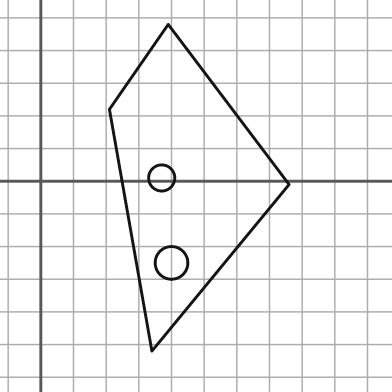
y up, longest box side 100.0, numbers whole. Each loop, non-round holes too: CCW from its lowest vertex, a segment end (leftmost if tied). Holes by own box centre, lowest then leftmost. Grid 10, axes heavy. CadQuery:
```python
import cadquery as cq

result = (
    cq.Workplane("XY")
    .moveTo(34.0, -52.0)
    .lineTo(76.0, -1.0)
    .lineTo(39.0, 48.0)
    .lineTo(21.0, 22.0)
    .close()
    .moveTo(40.0, -25.0)
    .circle(5.0)
    .moveTo(37.0, 1.0)
    .circle(4.0)
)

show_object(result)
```